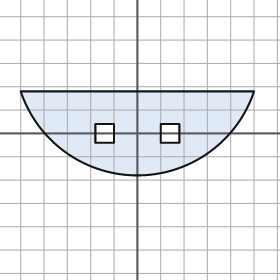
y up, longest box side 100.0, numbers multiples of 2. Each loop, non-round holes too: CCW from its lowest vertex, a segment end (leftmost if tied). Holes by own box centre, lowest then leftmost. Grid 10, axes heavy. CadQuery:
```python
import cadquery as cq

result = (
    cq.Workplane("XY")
    .moveTo(-50.0, 18.0)
    .threePointArc((0.0, -18.0), (50.0, 18.0))
    .close()
    .moveTo(-18.0, -4.0)
    .lineTo(-10.0, -4.0)
    .lineTo(-10.0, 4.0)
    .lineTo(-18.0, 4.0)
    .close()
    .moveTo(10.0, -4.0)
    .lineTo(18.0, -4.0)
    .lineTo(18.0, 4.0)
    .lineTo(10.0, 4.0)
    .close()
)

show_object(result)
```